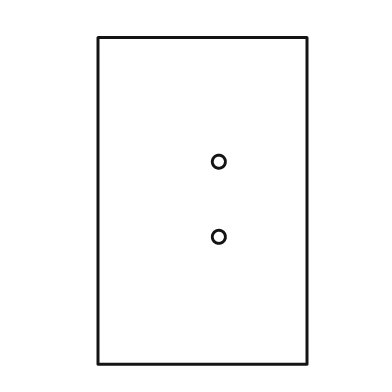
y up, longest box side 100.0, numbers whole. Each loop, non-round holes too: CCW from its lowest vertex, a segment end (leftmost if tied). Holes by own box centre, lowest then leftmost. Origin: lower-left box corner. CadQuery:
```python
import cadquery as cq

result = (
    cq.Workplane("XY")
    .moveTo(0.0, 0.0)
    .lineTo(64.0, 0.0)
    .lineTo(64.0, 100.0)
    .lineTo(0.0, 100.0)
    .close()
    .moveTo(37.0, 39.0)
    .circle(2.0)
    .moveTo(37.0, 62.0)
    .circle(2.0)
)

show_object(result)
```